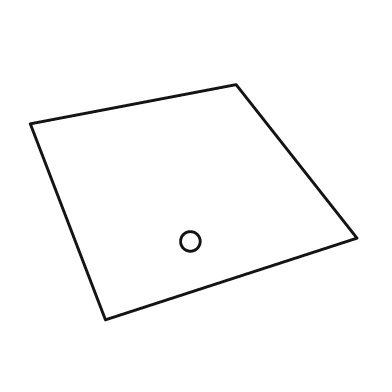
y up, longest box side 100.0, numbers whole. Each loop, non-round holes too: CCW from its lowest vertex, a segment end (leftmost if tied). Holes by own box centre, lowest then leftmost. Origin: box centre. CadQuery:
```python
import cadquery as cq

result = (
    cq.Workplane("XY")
    .moveTo(-27.0, -36.0)
    .lineTo(50.0, -11.0)
    .lineTo(13.0, 36.0)
    .lineTo(-50.0, 24.0)
    .close()
    .moveTo(-1.0, -12.0)
    .circle(3.0)
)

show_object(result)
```